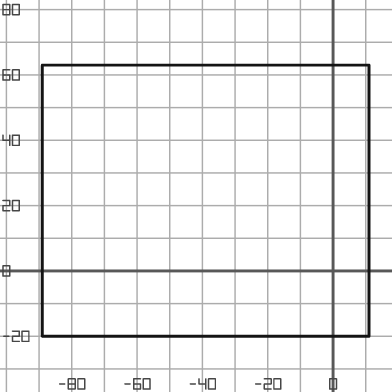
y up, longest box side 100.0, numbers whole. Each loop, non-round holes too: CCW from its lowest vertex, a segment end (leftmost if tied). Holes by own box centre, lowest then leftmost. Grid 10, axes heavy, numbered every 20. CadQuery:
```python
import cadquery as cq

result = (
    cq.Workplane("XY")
    .moveTo(-89.0, -20.0)
    .lineTo(11.0, -20.0)
    .lineTo(11.0, 63.0)
    .lineTo(-89.0, 63.0)
    .close()
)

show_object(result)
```